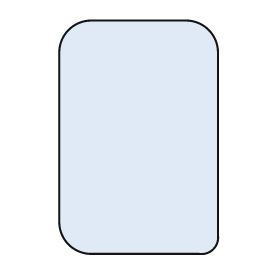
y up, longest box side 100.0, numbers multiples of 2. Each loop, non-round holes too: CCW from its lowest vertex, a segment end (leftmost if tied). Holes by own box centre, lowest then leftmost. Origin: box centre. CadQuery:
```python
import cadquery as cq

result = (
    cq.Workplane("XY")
    .moveTo(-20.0, -50.0)
    .lineTo(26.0, -50.0)
    .threePointArc((32.0, -48.0), (34.0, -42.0))
    .lineTo(34.0, 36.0)
    .threePointArc((30.0, 46.0), (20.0, 50.0))
    .lineTo(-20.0, 50.0)
    .threePointArc((-30.0, 46.0), (-34.0, 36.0))
    .lineTo(-34.0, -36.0)
    .threePointArc((-30.0, -46.0), (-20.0, -50.0))
    .close()
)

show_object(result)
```